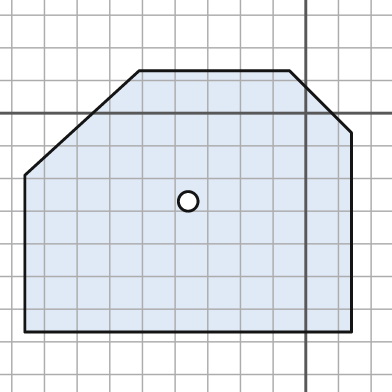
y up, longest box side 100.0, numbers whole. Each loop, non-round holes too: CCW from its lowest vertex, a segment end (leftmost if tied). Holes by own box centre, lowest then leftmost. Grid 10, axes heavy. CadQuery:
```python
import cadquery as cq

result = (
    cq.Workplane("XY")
    .moveTo(-86.0, -67.0)
    .lineTo(14.0, -67.0)
    .lineTo(14.0, -6.0)
    .lineTo(-5.0, 13.0)
    .lineTo(-51.0, 13.0)
    .lineTo(-86.0, -19.0)
    .close()
    .moveTo(-36.0, -27.0)
    .circle(3.0)
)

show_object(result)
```